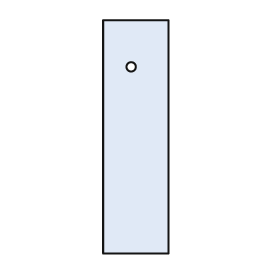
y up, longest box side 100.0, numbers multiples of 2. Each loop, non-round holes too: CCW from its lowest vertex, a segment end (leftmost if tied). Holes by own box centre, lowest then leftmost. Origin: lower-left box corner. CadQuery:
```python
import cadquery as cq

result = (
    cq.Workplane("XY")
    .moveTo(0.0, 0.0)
    .lineTo(28.0, 0.0)
    .lineTo(28.0, 100.0)
    .lineTo(0.0, 100.0)
    .close()
    .moveTo(12.0, 80.0)
    .circle(2.0)
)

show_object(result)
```